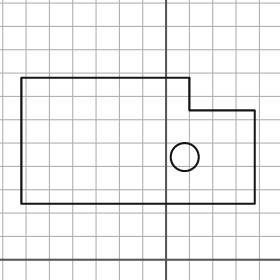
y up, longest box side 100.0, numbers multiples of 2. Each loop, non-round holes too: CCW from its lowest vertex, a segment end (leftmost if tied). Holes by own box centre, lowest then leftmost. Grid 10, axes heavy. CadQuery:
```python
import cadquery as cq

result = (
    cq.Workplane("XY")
    .moveTo(-62.0, 24.0)
    .lineTo(38.0, 24.0)
    .lineTo(38.0, 64.0)
    .lineTo(10.0, 64.0)
    .lineTo(10.0, 78.0)
    .lineTo(-62.0, 78.0)
    .close()
    .moveTo(8.0, 44.0)
    .circle(6.0)
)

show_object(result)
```